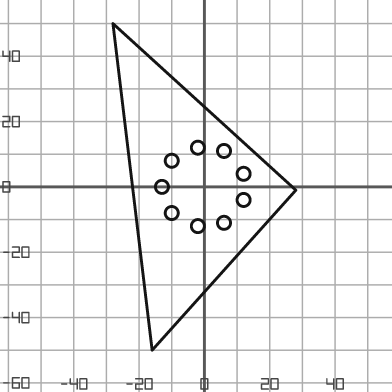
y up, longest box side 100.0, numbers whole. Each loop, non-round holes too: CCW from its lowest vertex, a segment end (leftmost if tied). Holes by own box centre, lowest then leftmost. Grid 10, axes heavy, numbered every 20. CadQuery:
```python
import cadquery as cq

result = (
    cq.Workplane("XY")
    .moveTo(-16.0, -50.0)
    .lineTo(28.0, -1.0)
    .lineTo(-28.0, 50.0)
    .close()
    .moveTo(-2.0, -12.0)
    .circle(2.0)
    .moveTo(6.0, -11.0)
    .circle(2.0)
    .moveTo(-10.0, -8.0)
    .circle(2.0)
    .moveTo(12.0, -4.0)
    .circle(2.0)
    .moveTo(-13.0, 0.0)
    .circle(2.0)
    .moveTo(12.0, 4.0)
    .circle(2.0)
    .moveTo(-10.0, 8.0)
    .circle(2.0)
    .moveTo(6.0, 11.0)
    .circle(2.0)
    .moveTo(-2.0, 12.0)
    .circle(2.0)
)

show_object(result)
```